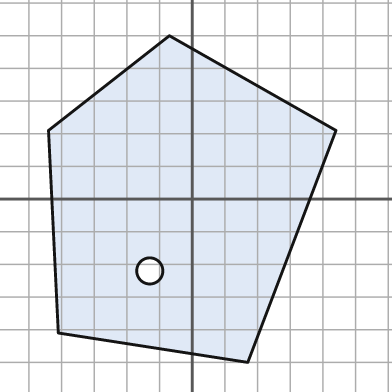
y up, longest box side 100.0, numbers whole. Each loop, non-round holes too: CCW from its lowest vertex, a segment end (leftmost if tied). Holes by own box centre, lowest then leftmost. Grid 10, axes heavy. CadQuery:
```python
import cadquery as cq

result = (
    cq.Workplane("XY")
    .moveTo(17.0, -50.0)
    .lineTo(44.0, 21.0)
    .lineTo(-7.0, 50.0)
    .lineTo(-44.0, 21.0)
    .lineTo(-41.0, -41.0)
    .close()
    .moveTo(-13.0, -22.0)
    .circle(4.0)
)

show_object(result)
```